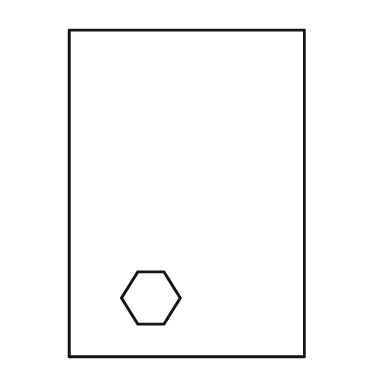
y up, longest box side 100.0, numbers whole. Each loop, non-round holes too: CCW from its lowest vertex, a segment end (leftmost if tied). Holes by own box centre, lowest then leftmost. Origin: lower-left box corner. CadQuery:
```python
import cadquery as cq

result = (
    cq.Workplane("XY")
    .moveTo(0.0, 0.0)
    .lineTo(72.0, 0.0)
    .lineTo(72.0, 100.0)
    .lineTo(0.0, 100.0)
    .close()
    .moveTo(21.0, 10.0)
    .lineTo(29.0, 10.0)
    .lineTo(34.0, 18.0)
    .lineTo(29.0, 26.0)
    .lineTo(21.0, 26.0)
    .lineTo(16.0, 18.0)
    .close()
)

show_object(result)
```